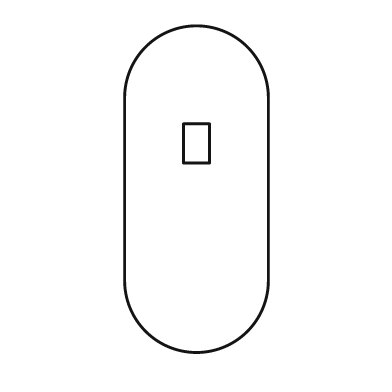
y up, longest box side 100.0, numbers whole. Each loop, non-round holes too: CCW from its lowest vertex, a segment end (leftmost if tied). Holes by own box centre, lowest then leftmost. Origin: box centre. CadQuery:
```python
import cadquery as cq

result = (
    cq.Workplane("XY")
    .moveTo(-22.0, -28.0)
    .threePointArc((0.0, -50.0), (22.0, -28.0))
    .lineTo(22.0, 28.0)
    .threePointArc((0.0, 50.0), (-22.0, 28.0))
    .close()
    .moveTo(-4.0, 8.0)
    .lineTo(4.0, 8.0)
    .lineTo(4.0, 20.0)
    .lineTo(-4.0, 20.0)
    .close()
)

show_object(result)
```